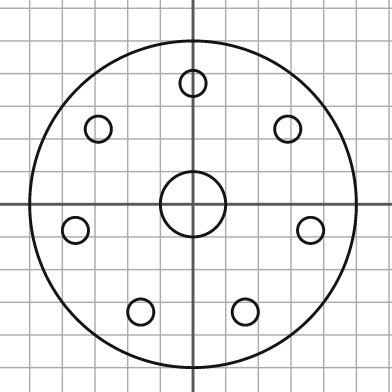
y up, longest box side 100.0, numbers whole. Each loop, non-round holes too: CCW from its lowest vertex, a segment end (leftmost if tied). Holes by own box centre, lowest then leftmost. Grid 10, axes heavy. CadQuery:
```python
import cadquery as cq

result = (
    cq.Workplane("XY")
    .moveTo(0.0, 0.0)
    .circle(50.0)
    .moveTo(-16.0, -33.0)
    .circle(4.0)
    .moveTo(16.0, -33.0)
    .circle(4.0)
    .moveTo(-36.0, -8.0)
    .circle(4.0)
    .moveTo(36.0, -8.0)
    .circle(4.0)
    .moveTo(0.0, 0.0)
    .circle(10.0)
    .moveTo(-29.0, 23.0)
    .circle(4.0)
    .moveTo(29.0, 23.0)
    .circle(4.0)
    .moveTo(0.0, 37.0)
    .circle(4.0)
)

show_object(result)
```